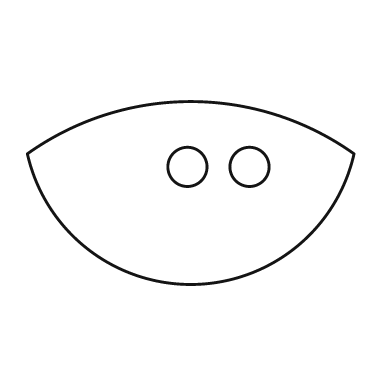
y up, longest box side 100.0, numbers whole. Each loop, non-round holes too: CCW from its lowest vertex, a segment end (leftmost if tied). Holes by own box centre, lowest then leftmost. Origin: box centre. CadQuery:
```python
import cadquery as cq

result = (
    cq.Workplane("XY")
    .moveTo(-50.0, 12.0)
    .threePointArc((0.0, -28.0), (50.0, 12.0))
    .threePointArc((0.0, 28.0), (-50.0, 12.0))
    .close()
    .moveTo(-1.0, 8.0)
    .circle(6.0)
    .moveTo(18.0, 8.0)
    .circle(6.0)
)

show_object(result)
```